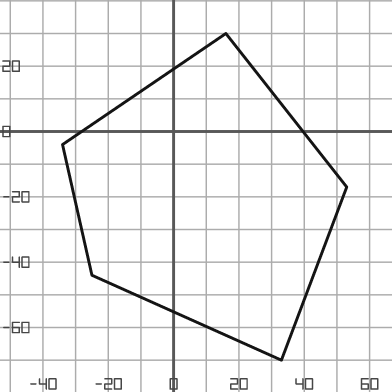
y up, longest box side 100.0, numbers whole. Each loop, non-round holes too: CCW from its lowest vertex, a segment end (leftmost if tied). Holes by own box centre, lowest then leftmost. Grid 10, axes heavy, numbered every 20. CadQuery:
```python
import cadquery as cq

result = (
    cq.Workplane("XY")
    .moveTo(33.0, -70.0)
    .lineTo(53.0, -17.0)
    .lineTo(16.0, 30.0)
    .lineTo(-34.0, -4.0)
    .lineTo(-25.0, -44.0)
    .close()
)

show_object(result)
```